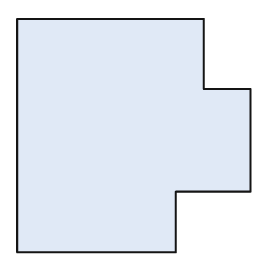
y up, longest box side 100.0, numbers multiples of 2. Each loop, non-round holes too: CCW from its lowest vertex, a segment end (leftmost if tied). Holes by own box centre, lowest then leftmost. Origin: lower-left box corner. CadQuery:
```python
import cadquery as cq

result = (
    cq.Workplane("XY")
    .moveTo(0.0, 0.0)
    .lineTo(68.0, 0.0)
    .lineTo(68.0, 26.0)
    .lineTo(100.0, 26.0)
    .lineTo(100.0, 70.0)
    .lineTo(80.0, 70.0)
    .lineTo(80.0, 100.0)
    .lineTo(0.0, 100.0)
    .close()
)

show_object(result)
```